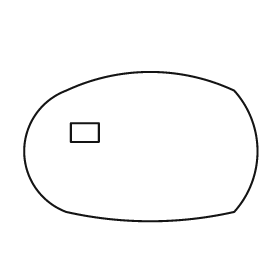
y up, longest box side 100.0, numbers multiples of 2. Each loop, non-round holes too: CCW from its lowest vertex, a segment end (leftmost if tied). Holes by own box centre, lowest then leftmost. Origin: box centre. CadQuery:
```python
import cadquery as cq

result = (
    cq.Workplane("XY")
    .moveTo(-32.0, -28.0)
    .threePointArc((4.0, -32.0), (40.0, -28.0))
    .threePointArc((50.0, -2.0), (40.0, 24.0))
    .threePointArc((4.0, 32.0), (-32.0, 24.0))
    .threePointArc((-50.0, -2.0), (-32.0, -28.0))
    .close()
    .moveTo(-30.0, 2.0)
    .lineTo(-18.0, 2.0)
    .lineTo(-18.0, 10.0)
    .lineTo(-30.0, 10.0)
    .close()
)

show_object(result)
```